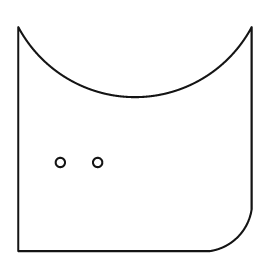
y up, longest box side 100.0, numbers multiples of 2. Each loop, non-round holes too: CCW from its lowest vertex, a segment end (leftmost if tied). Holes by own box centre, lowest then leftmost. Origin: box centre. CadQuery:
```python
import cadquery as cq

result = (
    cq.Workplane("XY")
    .moveTo(-50.0, -48.0)
    .lineTo(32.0, -48.0)
    .threePointArc((44.0, -42.0), (50.0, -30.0))
    .lineTo(50.0, 48.0)
    .threePointArc((0.0, 18.0), (-50.0, 48.0))
    .close()
    .moveTo(-32.0, -10.0)
    .circle(2.0)
    .moveTo(-16.0, -10.0)
    .circle(2.0)
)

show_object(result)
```